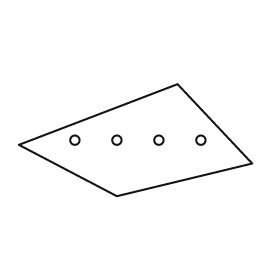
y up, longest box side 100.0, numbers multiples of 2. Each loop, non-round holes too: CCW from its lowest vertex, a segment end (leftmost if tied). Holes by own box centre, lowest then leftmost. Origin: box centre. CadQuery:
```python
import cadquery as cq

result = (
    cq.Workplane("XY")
    .moveTo(-8.0, -24.0)
    .lineTo(50.0, -10.0)
    .lineTo(18.0, 24.0)
    .lineTo(-50.0, -2.0)
    .close()
    .moveTo(-26.0, 0.0)
    .circle(2.0)
    .moveTo(-8.0, 0.0)
    .circle(2.0)
    .moveTo(10.0, 0.0)
    .circle(2.0)
    .moveTo(28.0, 0.0)
    .circle(2.0)
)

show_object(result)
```